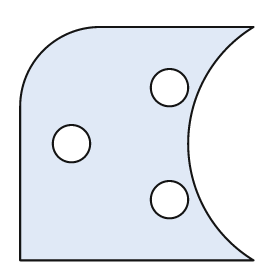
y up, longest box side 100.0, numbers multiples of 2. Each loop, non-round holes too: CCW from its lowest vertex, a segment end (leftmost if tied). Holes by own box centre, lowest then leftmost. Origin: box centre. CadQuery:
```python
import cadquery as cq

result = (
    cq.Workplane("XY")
    .moveTo(-50.0, -50.0)
    .lineTo(50.0, -50.0)
    .threePointArc((22.0, 0.0), (50.0, 50.0))
    .lineTo(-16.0, 50.0)
    .threePointArc((-40.0, 40.0), (-50.0, 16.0))
    .close()
    .moveTo(14.0, -24.0)
    .circle(8.0)
    .moveTo(-28.0, 0.0)
    .circle(8.0)
    .moveTo(14.0, 24.0)
    .circle(8.0)
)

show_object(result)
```